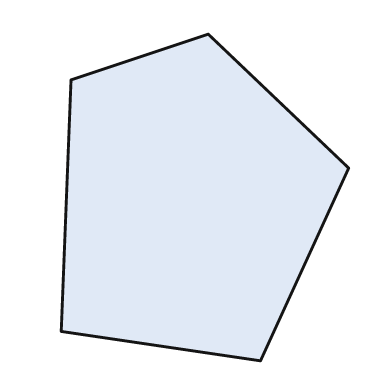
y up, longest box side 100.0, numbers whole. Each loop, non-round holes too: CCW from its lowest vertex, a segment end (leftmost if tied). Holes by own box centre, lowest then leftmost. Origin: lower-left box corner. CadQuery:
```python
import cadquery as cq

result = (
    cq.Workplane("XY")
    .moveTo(61.0, 0.0)
    .lineTo(88.0, 59.0)
    .lineTo(45.0, 100.0)
    .lineTo(3.0, 86.0)
    .lineTo(0.0, 9.0)
    .close()
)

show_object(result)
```